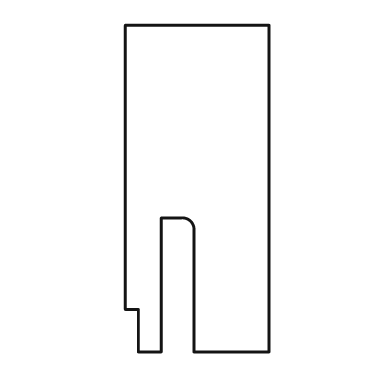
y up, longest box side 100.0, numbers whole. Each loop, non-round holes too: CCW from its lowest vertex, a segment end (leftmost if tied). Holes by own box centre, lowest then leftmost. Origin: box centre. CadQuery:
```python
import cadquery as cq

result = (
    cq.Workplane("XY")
    .moveTo(-18.0, -50.0)
    .lineTo(-11.0, -50.0)
    .lineTo(-11.0, -9.0)
    .lineTo(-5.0, -9.0)
    .threePointArc((-2.0, -10.0), (-1.0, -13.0))
    .lineTo(-1.0, -50.0)
    .lineTo(22.0, -50.0)
    .lineTo(22.0, 50.0)
    .lineTo(-22.0, 50.0)
    .lineTo(-22.0, -37.0)
    .lineTo(-18.0, -37.0)
    .close()
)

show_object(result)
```